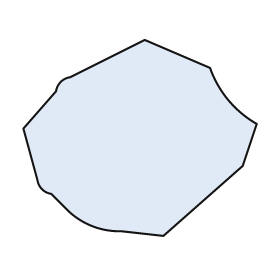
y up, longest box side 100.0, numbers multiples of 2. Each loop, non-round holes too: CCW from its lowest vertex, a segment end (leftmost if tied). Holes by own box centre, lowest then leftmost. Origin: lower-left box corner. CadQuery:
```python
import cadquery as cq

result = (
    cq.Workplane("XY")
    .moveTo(60.0, 0.0)
    .lineTo(94.0, 30.0)
    .lineTo(100.0, 48.0)
    .threePointArc((88.0, 58.0), (80.0, 72.0))
    .lineTo(52.0, 84.0)
    .lineTo(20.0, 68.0)
    .threePointArc((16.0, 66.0), (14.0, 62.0))
    .lineTo(0.0, 46.0)
    .lineTo(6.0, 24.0)
    .threePointArc((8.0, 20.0), (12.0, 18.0))
    .lineTo(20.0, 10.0)
    .threePointArc((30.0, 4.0), (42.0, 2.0))
    .close()
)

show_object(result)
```